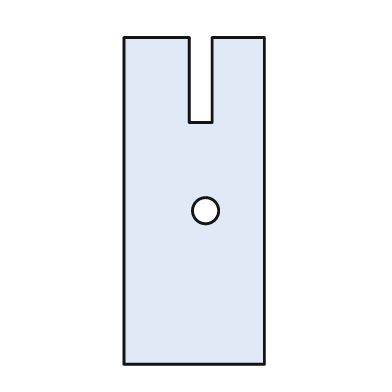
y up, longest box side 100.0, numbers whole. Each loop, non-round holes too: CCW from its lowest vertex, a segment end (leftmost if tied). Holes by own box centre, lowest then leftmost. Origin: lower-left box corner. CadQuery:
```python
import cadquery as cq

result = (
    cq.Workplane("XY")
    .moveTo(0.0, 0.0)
    .lineTo(43.0, 0.0)
    .lineTo(43.0, 100.0)
    .lineTo(27.0, 100.0)
    .lineTo(27.0, 74.0)
    .lineTo(20.0, 74.0)
    .lineTo(20.0, 100.0)
    .lineTo(0.0, 100.0)
    .close()
    .moveTo(25.0, 47.0)
    .circle(4.0)
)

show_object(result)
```